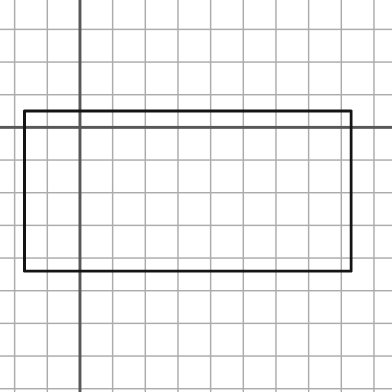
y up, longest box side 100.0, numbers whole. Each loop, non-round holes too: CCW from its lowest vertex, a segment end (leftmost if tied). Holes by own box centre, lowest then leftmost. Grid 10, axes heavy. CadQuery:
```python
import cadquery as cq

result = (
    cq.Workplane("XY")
    .moveTo(-17.0, -44.0)
    .lineTo(83.0, -44.0)
    .lineTo(83.0, 5.0)
    .lineTo(-17.0, 5.0)
    .close()
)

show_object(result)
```